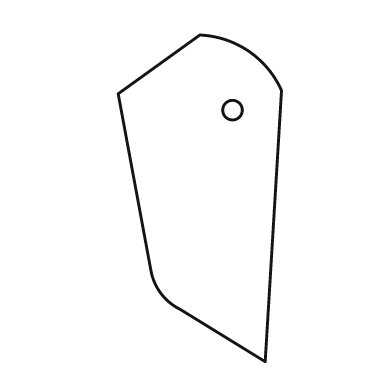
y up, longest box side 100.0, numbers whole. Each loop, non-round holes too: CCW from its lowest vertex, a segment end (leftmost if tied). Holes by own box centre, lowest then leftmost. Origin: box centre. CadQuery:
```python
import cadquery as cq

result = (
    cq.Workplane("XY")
    .moveTo(20.0, -50.0)
    .lineTo(25.0, 33.0)
    .threePointArc((15.0, 45.0), (0.0, 50.0))
    .lineTo(-25.0, 32.0)
    .lineTo(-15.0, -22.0)
    .threePointArc((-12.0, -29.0), (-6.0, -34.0))
    .close()
    .moveTo(10.0, 27.0)
    .circle(3.0)
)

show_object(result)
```